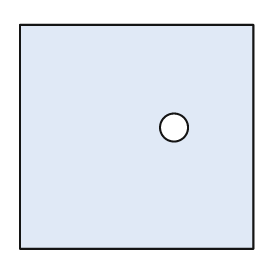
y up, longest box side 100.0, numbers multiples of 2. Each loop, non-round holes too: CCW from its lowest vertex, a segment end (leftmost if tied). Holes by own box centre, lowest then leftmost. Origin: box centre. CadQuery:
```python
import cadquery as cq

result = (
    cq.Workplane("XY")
    .moveTo(-50.0, -48.0)
    .lineTo(50.0, -48.0)
    .lineTo(50.0, 48.0)
    .lineTo(-50.0, 48.0)
    .close()
    .moveTo(16.0, 4.0)
    .circle(6.0)
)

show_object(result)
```